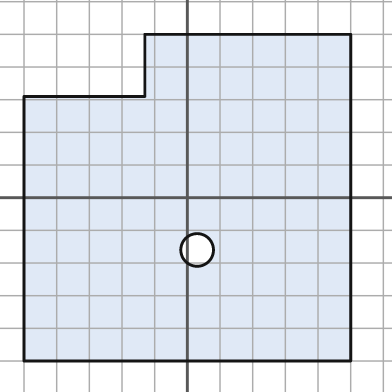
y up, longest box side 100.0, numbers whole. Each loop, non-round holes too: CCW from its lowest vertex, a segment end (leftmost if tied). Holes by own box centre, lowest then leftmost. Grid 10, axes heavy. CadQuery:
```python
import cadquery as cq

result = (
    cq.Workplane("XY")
    .moveTo(-50.0, -50.0)
    .lineTo(50.0, -50.0)
    .lineTo(50.0, 50.0)
    .lineTo(-13.0, 50.0)
    .lineTo(-13.0, 31.0)
    .lineTo(-50.0, 31.0)
    .close()
    .moveTo(3.0, -16.0)
    .circle(5.0)
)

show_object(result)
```